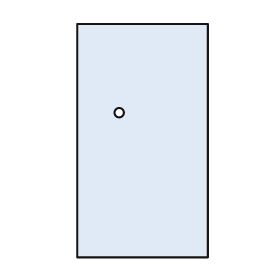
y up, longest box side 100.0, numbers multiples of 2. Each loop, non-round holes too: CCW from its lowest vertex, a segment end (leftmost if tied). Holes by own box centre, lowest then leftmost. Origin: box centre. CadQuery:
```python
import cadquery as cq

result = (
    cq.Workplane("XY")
    .moveTo(-28.0, -50.0)
    .lineTo(28.0, -50.0)
    .lineTo(28.0, 50.0)
    .lineTo(-28.0, 50.0)
    .close()
    .moveTo(-10.0, 12.0)
    .circle(2.0)
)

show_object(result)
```